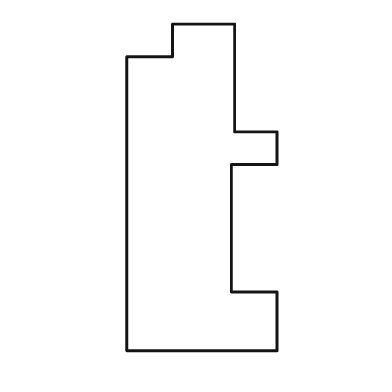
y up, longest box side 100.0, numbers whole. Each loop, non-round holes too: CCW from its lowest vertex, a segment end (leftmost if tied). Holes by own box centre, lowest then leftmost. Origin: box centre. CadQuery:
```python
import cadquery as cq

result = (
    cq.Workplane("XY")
    .moveTo(-23.0, -50.0)
    .lineTo(23.0, -50.0)
    .lineTo(23.0, -32.0)
    .lineTo(9.0, -32.0)
    .lineTo(9.0, 7.0)
    .lineTo(23.0, 7.0)
    .lineTo(23.0, 17.0)
    .lineTo(10.0, 17.0)
    .lineTo(10.0, 50.0)
    .lineTo(-9.0, 50.0)
    .lineTo(-9.0, 40.0)
    .lineTo(-23.0, 40.0)
    .close()
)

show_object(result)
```